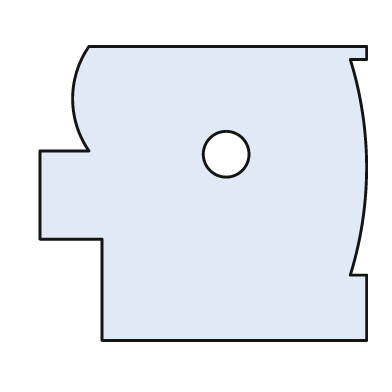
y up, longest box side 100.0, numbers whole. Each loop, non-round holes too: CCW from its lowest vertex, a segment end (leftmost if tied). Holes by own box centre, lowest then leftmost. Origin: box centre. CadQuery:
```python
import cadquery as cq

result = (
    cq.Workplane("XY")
    .moveTo(-31.0, -45.0)
    .lineTo(50.0, -45.0)
    .lineTo(50.0, -25.0)
    .lineTo(45.0, -25.0)
    .threePointArc((50.0, 8.0), (45.0, 41.0))
    .lineTo(50.0, 41.0)
    .lineTo(50.0, 45.0)
    .lineTo(-35.0, 45.0)
    .threePointArc((-40.0, 29.0), (-35.0, 13.0))
    .lineTo(-50.0, 13.0)
    .lineTo(-50.0, -14.0)
    .lineTo(-31.0, -14.0)
    .close()
    .moveTo(7.0, 12.0)
    .circle(7.0)
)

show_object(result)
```